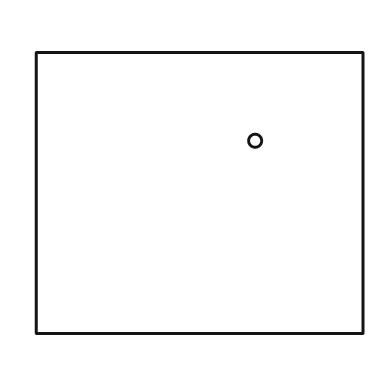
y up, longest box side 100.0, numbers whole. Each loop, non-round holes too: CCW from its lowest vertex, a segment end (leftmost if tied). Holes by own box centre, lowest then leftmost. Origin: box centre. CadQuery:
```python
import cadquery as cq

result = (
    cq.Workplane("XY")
    .moveTo(-50.0, -43.0)
    .lineTo(50.0, -43.0)
    .lineTo(50.0, 43.0)
    .lineTo(-50.0, 43.0)
    .close()
    .moveTo(17.0, 16.0)
    .circle(2.0)
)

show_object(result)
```